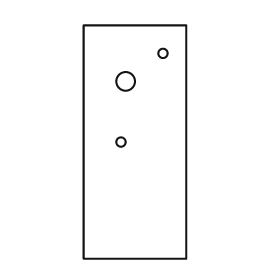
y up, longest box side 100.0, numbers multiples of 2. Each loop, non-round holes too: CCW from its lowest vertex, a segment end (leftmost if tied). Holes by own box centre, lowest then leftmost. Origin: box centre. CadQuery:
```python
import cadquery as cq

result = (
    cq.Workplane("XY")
    .moveTo(-22.0, -50.0)
    .lineTo(22.0, -50.0)
    .lineTo(22.0, 50.0)
    .lineTo(-22.0, 50.0)
    .close()
    .moveTo(-6.0, 0.0)
    .circle(2.0)
    .moveTo(-4.0, 26.0)
    .circle(4.0)
    .moveTo(12.0, 38.0)
    .circle(2.0)
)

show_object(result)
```